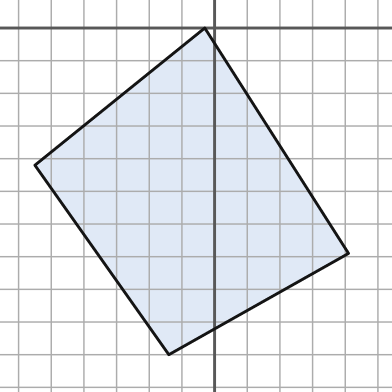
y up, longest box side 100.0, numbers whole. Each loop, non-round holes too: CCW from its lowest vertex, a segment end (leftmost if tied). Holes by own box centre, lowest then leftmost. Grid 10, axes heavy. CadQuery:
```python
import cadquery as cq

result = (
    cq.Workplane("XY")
    .moveTo(-14.0, -100.0)
    .lineTo(41.0, -69.0)
    .lineTo(-3.0, 0.0)
    .lineTo(-55.0, -42.0)
    .close()
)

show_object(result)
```